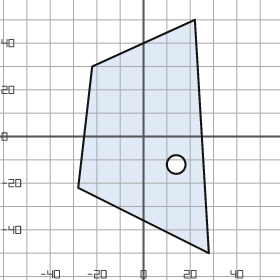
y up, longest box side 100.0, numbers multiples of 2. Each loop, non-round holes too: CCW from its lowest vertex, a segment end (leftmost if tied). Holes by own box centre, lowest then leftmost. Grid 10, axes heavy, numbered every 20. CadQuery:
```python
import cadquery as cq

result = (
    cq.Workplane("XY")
    .moveTo(28.0, -50.0)
    .lineTo(22.0, 50.0)
    .lineTo(-22.0, 30.0)
    .lineTo(-28.0, -22.0)
    .close()
    .moveTo(14.0, -12.0)
    .circle(4.0)
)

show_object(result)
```